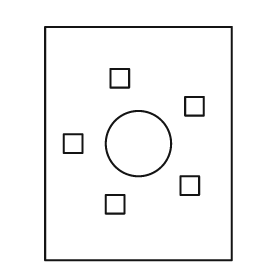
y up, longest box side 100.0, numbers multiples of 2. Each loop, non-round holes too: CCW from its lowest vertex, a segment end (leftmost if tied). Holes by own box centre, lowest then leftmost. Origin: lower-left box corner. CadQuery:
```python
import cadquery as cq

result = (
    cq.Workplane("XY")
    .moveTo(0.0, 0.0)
    .lineTo(80.0, 0.0)
    .lineTo(80.0, 100.0)
    .lineTo(0.0, 100.0)
    .close()
    .moveTo(26.0, 20.0)
    .lineTo(34.0, 20.0)
    .lineTo(34.0, 28.0)
    .lineTo(26.0, 28.0)
    .close()
    .moveTo(58.0, 28.0)
    .lineTo(66.0, 28.0)
    .lineTo(66.0, 36.0)
    .lineTo(58.0, 36.0)
    .close()
    .moveTo(8.0, 46.0)
    .lineTo(16.0, 46.0)
    .lineTo(16.0, 54.0)
    .lineTo(8.0, 54.0)
    .close()
    .moveTo(40.0, 50.0)
    .circle(14.0)
    .moveTo(60.0, 62.0)
    .lineTo(68.0, 62.0)
    .lineTo(68.0, 70.0)
    .lineTo(60.0, 70.0)
    .close()
    .moveTo(28.0, 74.0)
    .lineTo(36.0, 74.0)
    .lineTo(36.0, 82.0)
    .lineTo(28.0, 82.0)
    .close()
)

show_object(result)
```